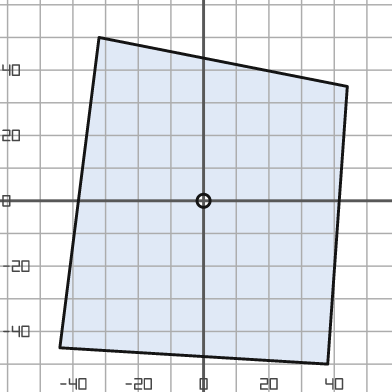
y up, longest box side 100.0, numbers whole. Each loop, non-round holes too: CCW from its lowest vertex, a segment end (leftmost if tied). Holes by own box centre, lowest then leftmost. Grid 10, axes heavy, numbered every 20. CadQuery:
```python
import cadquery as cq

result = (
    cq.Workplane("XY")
    .moveTo(38.0, -50.0)
    .lineTo(44.0, 35.0)
    .lineTo(-32.0, 50.0)
    .lineTo(-44.0, -45.0)
    .close()
    .moveTo(0.0, 0.0)
    .circle(2.0)
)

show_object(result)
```